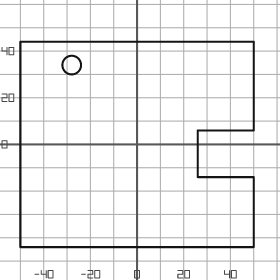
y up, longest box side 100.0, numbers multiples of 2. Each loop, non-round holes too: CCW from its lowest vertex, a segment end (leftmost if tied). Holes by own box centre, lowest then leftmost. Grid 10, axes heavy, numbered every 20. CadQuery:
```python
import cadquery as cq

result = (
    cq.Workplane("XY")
    .moveTo(-50.0, -44.0)
    .lineTo(50.0, -44.0)
    .lineTo(50.0, -14.0)
    .lineTo(26.0, -14.0)
    .lineTo(26.0, 6.0)
    .lineTo(50.0, 6.0)
    .lineTo(50.0, 44.0)
    .lineTo(-50.0, 44.0)
    .close()
    .moveTo(-28.0, 34.0)
    .circle(4.0)
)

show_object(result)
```